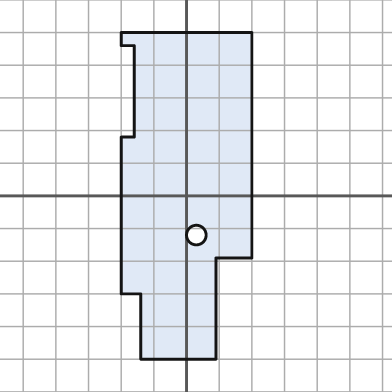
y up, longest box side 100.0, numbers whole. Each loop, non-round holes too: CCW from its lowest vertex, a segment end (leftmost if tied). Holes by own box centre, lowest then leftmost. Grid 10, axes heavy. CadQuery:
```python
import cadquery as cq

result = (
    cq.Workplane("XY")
    .moveTo(-14.0, -50.0)
    .lineTo(9.0, -50.0)
    .lineTo(9.0, -19.0)
    .lineTo(20.0, -19.0)
    .lineTo(20.0, 50.0)
    .lineTo(-20.0, 50.0)
    .lineTo(-20.0, 46.0)
    .lineTo(-16.0, 46.0)
    .lineTo(-16.0, 18.0)
    .lineTo(-20.0, 18.0)
    .lineTo(-20.0, -30.0)
    .lineTo(-14.0, -30.0)
    .close()
    .moveTo(3.0, -12.0)
    .circle(3.0)
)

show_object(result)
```